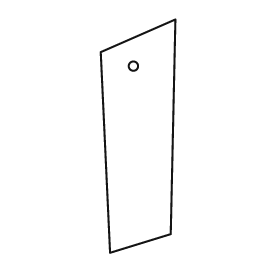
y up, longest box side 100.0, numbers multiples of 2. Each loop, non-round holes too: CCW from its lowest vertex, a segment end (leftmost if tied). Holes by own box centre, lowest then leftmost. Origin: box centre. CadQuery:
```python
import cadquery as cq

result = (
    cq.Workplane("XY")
    .moveTo(-12.0, -50.0)
    .lineTo(14.0, -42.0)
    .lineTo(16.0, 50.0)
    .lineTo(-16.0, 36.0)
    .close()
    .moveTo(-2.0, 30.0)
    .circle(2.0)
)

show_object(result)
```